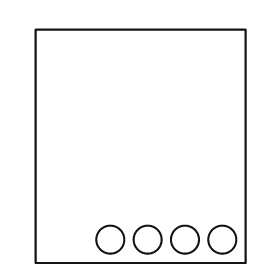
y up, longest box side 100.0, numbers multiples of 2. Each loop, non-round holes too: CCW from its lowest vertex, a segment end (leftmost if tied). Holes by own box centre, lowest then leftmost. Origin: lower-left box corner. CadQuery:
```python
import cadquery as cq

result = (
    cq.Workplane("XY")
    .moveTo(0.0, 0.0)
    .lineTo(90.0, 0.0)
    .lineTo(90.0, 100.0)
    .lineTo(0.0, 100.0)
    .close()
    .moveTo(32.0, 10.0)
    .circle(6.0)
    .moveTo(48.0, 10.0)
    .circle(6.0)
    .moveTo(64.0, 10.0)
    .circle(6.0)
    .moveTo(80.0, 10.0)
    .circle(6.0)
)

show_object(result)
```